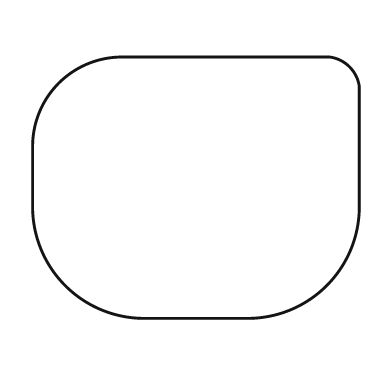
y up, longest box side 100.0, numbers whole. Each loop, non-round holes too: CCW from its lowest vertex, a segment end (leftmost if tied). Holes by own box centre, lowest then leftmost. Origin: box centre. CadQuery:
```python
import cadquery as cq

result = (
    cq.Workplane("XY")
    .moveTo(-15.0, -40.0)
    .lineTo(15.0, -40.0)
    .threePointArc((40.0, -30.0), (50.0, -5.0))
    .lineTo(50.0, 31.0)
    .threePointArc((47.0, 37.0), (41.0, 40.0))
    .lineTo(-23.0, 40.0)
    .threePointArc((-42.0, 32.0), (-50.0, 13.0))
    .lineTo(-50.0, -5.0)
    .threePointArc((-40.0, -30.0), (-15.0, -40.0))
    .close()
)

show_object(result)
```